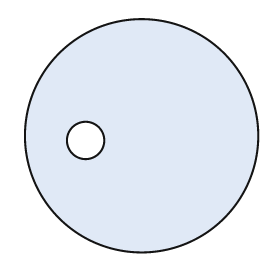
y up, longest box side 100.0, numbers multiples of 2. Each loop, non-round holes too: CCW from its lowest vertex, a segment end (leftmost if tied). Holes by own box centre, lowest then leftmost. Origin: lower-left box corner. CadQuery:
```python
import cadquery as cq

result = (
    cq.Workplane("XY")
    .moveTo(50.0, 50.0)
    .circle(50.0)
    .moveTo(26.0, 48.0)
    .circle(8.0)
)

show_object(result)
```